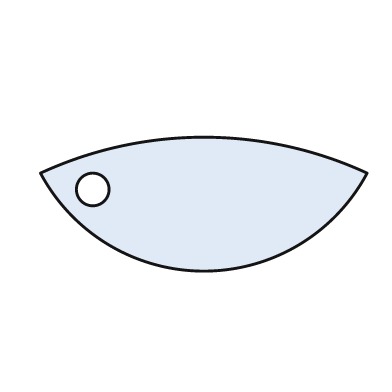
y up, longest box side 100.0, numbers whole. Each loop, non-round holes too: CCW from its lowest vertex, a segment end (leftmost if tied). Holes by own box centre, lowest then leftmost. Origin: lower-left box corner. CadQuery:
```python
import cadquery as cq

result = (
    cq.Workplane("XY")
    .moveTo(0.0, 30.0)
    .threePointArc((50.0, 0.0), (100.0, 30.0))
    .threePointArc((50.0, 41.0), (0.0, 30.0))
    .close()
    .moveTo(16.0, 25.0)
    .circle(5.0)
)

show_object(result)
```